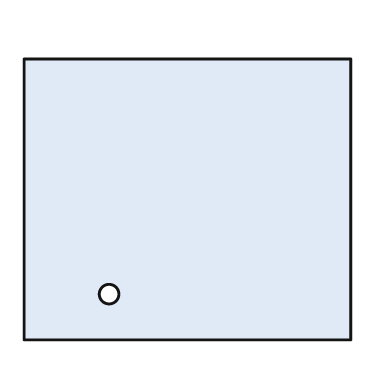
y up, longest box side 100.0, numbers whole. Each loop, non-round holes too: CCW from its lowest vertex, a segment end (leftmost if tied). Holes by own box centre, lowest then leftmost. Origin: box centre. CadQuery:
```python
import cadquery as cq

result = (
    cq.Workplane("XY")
    .moveTo(-50.0, -43.0)
    .lineTo(50.0, -43.0)
    .lineTo(50.0, 43.0)
    .lineTo(-50.0, 43.0)
    .close()
    .moveTo(-24.0, -29.0)
    .circle(3.0)
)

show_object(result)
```